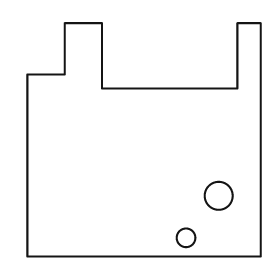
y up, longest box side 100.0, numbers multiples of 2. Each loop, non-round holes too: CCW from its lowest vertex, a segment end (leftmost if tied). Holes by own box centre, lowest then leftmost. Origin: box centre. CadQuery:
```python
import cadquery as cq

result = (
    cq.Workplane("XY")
    .moveTo(-50.0, -50.0)
    .lineTo(50.0, -50.0)
    .lineTo(50.0, 50.0)
    .lineTo(40.0, 50.0)
    .lineTo(40.0, 22.0)
    .lineTo(-18.0, 22.0)
    .lineTo(-18.0, 50.0)
    .lineTo(-34.0, 50.0)
    .lineTo(-34.0, 28.0)
    .lineTo(-50.0, 28.0)
    .close()
    .moveTo(18.0, -42.0)
    .circle(4.0)
    .moveTo(32.0, -24.0)
    .circle(6.0)
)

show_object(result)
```